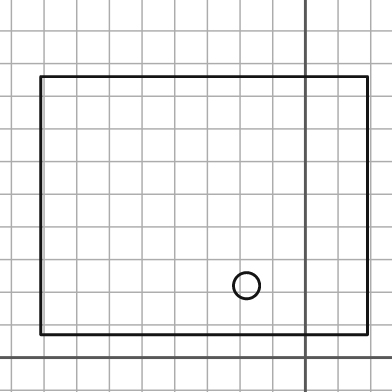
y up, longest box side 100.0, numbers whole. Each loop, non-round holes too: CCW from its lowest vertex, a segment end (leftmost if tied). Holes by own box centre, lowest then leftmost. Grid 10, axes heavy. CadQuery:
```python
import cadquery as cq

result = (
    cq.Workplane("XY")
    .moveTo(-81.0, 7.0)
    .lineTo(19.0, 7.0)
    .lineTo(19.0, 86.0)
    .lineTo(-81.0, 86.0)
    .close()
    .moveTo(-18.0, 22.0)
    .circle(4.0)
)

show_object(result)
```